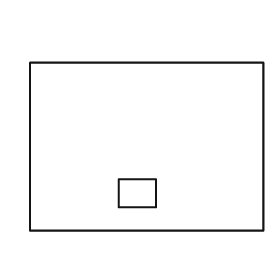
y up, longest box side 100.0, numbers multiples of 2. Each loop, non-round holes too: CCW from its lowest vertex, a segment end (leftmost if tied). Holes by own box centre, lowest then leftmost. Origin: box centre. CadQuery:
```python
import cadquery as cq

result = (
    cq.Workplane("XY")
    .moveTo(-50.0, -36.0)
    .lineTo(50.0, -36.0)
    .lineTo(50.0, 36.0)
    .lineTo(-50.0, 36.0)
    .close()
    .moveTo(-12.0, -26.0)
    .lineTo(4.0, -26.0)
    .lineTo(4.0, -14.0)
    .lineTo(-12.0, -14.0)
    .close()
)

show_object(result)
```